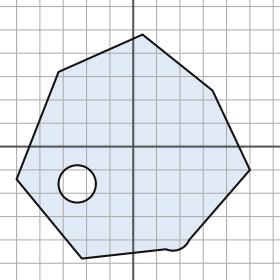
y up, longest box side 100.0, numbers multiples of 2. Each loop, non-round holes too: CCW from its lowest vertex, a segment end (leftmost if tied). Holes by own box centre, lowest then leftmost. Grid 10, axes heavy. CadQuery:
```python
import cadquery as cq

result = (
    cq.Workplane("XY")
    .moveTo(-22.0, -48.0)
    .lineTo(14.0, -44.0)
    .threePointArc((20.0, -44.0), (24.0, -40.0))
    .lineTo(50.0, -10.0)
    .lineTo(34.0, 24.0)
    .lineTo(4.0, 48.0)
    .lineTo(-32.0, 32.0)
    .lineTo(-50.0, -14.0)
    .close()
    .moveTo(-24.0, -16.0)
    .circle(8.0)
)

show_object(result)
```